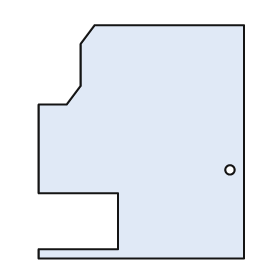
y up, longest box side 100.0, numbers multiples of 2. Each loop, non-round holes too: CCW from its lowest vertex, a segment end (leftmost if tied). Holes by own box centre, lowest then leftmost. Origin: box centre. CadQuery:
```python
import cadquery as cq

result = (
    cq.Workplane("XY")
    .moveTo(-44.0, -50.0)
    .lineTo(44.0, -50.0)
    .lineTo(44.0, 50.0)
    .lineTo(-20.0, 50.0)
    .lineTo(-26.0, 42.0)
    .lineTo(-26.0, 24.0)
    .lineTo(-32.0, 16.0)
    .lineTo(-44.0, 16.0)
    .lineTo(-44.0, -22.0)
    .lineTo(-10.0, -22.0)
    .lineTo(-10.0, -46.0)
    .lineTo(-44.0, -46.0)
    .close()
    .moveTo(38.0, -12.0)
    .circle(2.0)
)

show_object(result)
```